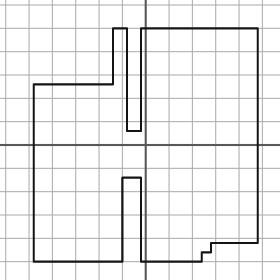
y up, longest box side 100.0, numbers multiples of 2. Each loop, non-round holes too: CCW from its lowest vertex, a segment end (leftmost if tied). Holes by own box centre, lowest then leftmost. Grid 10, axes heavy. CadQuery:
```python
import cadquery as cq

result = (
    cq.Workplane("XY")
    .moveTo(-48.0, -50.0)
    .lineTo(-10.0, -50.0)
    .lineTo(-10.0, -14.0)
    .lineTo(-2.0, -14.0)
    .lineTo(-2.0, -50.0)
    .lineTo(24.0, -50.0)
    .lineTo(24.0, -46.0)
    .lineTo(28.0, -46.0)
    .lineTo(28.0, -42.0)
    .lineTo(48.0, -42.0)
    .lineTo(48.0, 50.0)
    .lineTo(-2.0, 50.0)
    .lineTo(-2.0, 6.0)
    .lineTo(-8.0, 6.0)
    .lineTo(-8.0, 50.0)
    .lineTo(-14.0, 50.0)
    .lineTo(-14.0, 26.0)
    .lineTo(-48.0, 26.0)
    .close()
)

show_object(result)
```